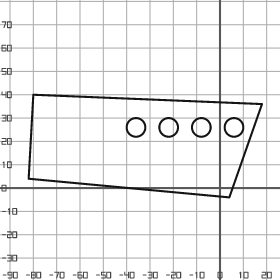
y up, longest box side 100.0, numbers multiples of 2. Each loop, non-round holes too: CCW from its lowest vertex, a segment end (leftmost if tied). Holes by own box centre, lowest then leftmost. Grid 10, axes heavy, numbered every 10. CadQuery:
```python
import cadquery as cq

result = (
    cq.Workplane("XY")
    .moveTo(4.0, -4.0)
    .lineTo(18.0, 36.0)
    .lineTo(-80.0, 40.0)
    .lineTo(-82.0, 4.0)
    .close()
    .moveTo(-36.0, 26.0)
    .circle(4.0)
    .moveTo(-22.0, 26.0)
    .circle(4.0)
    .moveTo(-8.0, 26.0)
    .circle(4.0)
    .moveTo(6.0, 26.0)
    .circle(4.0)
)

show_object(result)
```